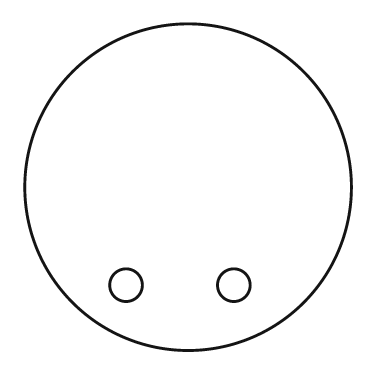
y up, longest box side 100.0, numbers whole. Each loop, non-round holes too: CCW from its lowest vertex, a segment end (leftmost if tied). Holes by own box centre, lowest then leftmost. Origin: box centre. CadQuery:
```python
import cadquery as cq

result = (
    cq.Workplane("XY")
    .moveTo(0.0, 0.0)
    .circle(50.0)
    .moveTo(-19.0, -30.0)
    .circle(5.0)
    .moveTo(14.0, -30.0)
    .circle(5.0)
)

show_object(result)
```